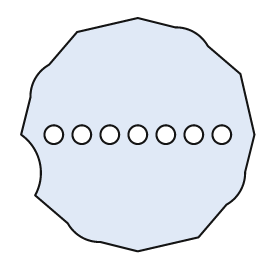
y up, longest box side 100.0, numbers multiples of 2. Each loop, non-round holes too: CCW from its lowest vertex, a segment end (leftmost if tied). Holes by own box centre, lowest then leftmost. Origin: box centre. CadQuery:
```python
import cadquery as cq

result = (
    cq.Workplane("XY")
    .moveTo(0.0, -50.0)
    .lineTo(26.0, -44.0)
    .lineTo(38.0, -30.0)
    .threePointArc((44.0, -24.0), (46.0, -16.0))
    .lineTo(50.0, 0.0)
    .lineTo(44.0, 26.0)
    .lineTo(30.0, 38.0)
    .threePointArc((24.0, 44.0), (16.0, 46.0))
    .lineTo(0.0, 50.0)
    .lineTo(-26.0, 44.0)
    .lineTo(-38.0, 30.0)
    .threePointArc((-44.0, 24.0), (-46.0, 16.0))
    .lineTo(-50.0, 0.0)
    .threePointArc((-42.0, -12.0), (-44.0, -26.0))
    .lineTo(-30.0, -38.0)
    .threePointArc((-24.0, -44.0), (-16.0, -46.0))
    .close()
    .moveTo(-36.0, 0.0)
    .circle(4.0)
    .moveTo(-24.0, 0.0)
    .circle(4.0)
    .moveTo(-12.0, 0.0)
    .circle(4.0)
    .moveTo(0.0, 0.0)
    .circle(4.0)
    .moveTo(12.0, 0.0)
    .circle(4.0)
    .moveTo(24.0, 0.0)
    .circle(4.0)
    .moveTo(36.0, 0.0)
    .circle(4.0)
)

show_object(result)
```